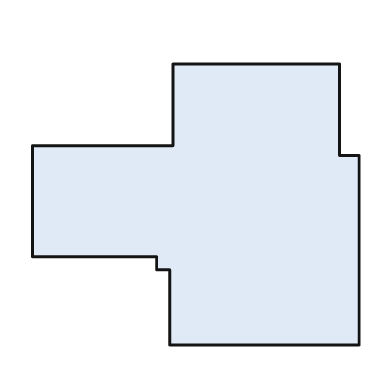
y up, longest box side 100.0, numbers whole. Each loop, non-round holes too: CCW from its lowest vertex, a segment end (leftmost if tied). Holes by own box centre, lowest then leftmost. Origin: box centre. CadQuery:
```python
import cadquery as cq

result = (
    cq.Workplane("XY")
    .moveTo(-8.0, -43.0)
    .lineTo(50.0, -43.0)
    .lineTo(50.0, 15.0)
    .lineTo(44.0, 15.0)
    .lineTo(44.0, 43.0)
    .lineTo(-7.0, 43.0)
    .lineTo(-7.0, 18.0)
    .lineTo(-50.0, 18.0)
    .lineTo(-50.0, -16.0)
    .lineTo(-12.0, -16.0)
    .lineTo(-12.0, -20.0)
    .lineTo(-8.0, -20.0)
    .close()
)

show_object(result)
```